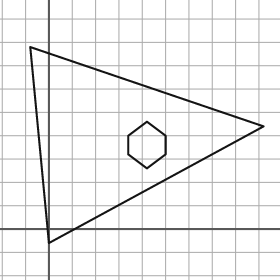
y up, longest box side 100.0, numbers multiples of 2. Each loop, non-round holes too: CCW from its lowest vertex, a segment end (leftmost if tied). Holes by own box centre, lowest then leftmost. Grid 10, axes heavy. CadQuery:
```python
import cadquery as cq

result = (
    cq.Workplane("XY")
    .moveTo(0.0, -6.0)
    .lineTo(92.0, 44.0)
    .lineTo(-8.0, 78.0)
    .close()
    .moveTo(42.0, 26.0)
    .lineTo(50.0, 32.0)
    .lineTo(50.0, 40.0)
    .lineTo(42.0, 46.0)
    .lineTo(34.0, 40.0)
    .lineTo(34.0, 32.0)
    .close()
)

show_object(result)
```